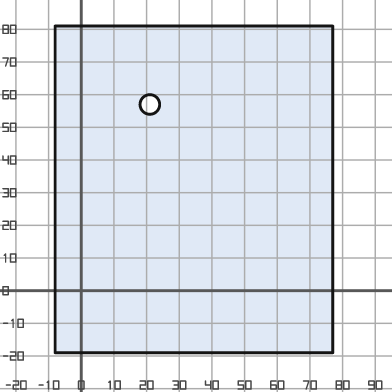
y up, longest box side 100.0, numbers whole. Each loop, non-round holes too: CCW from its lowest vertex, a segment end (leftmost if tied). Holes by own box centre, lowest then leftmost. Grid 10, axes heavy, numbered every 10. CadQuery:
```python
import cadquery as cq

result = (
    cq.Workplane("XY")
    .moveTo(-8.0, -19.0)
    .lineTo(77.0, -19.0)
    .lineTo(77.0, 81.0)
    .lineTo(-8.0, 81.0)
    .close()
    .moveTo(21.0, 57.0)
    .circle(3.0)
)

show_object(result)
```